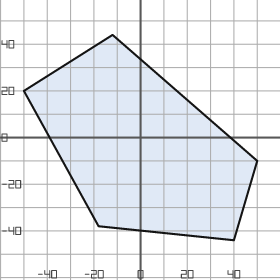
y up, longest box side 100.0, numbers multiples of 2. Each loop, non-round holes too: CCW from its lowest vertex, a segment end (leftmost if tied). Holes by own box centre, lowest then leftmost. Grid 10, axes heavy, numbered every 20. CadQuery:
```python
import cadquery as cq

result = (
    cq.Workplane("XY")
    .moveTo(40.0, -44.0)
    .lineTo(50.0, -10.0)
    .lineTo(-12.0, 44.0)
    .lineTo(-50.0, 20.0)
    .lineTo(-18.0, -38.0)
    .close()
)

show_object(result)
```